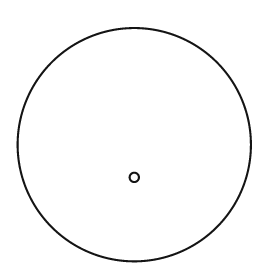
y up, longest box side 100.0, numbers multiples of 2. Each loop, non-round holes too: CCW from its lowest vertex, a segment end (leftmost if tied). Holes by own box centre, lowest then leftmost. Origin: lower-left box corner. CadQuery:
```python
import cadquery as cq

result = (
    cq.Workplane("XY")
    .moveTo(50.0, 50.0)
    .circle(50.0)
    .moveTo(50.0, 36.0)
    .circle(2.0)
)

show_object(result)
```